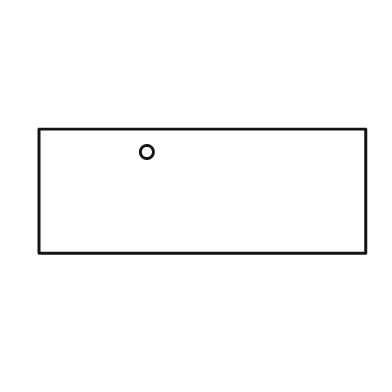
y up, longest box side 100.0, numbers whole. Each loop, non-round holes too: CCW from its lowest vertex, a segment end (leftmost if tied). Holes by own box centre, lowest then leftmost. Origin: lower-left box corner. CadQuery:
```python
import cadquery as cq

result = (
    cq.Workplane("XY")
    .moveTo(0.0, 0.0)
    .lineTo(100.0, 0.0)
    .lineTo(100.0, 38.0)
    .lineTo(0.0, 38.0)
    .close()
    .moveTo(33.0, 31.0)
    .circle(2.0)
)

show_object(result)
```